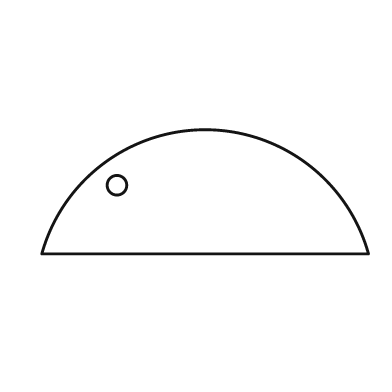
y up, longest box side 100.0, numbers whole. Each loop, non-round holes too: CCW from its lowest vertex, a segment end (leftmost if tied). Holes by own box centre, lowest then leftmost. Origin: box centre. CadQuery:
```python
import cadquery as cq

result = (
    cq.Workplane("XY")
    .moveTo(-50.0, -19.0)
    .lineTo(50.0, -19.0)
    .threePointArc((0.0, 19.0), (-50.0, -19.0))
    .close()
    .moveTo(-27.0, 2.0)
    .circle(3.0)
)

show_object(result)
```